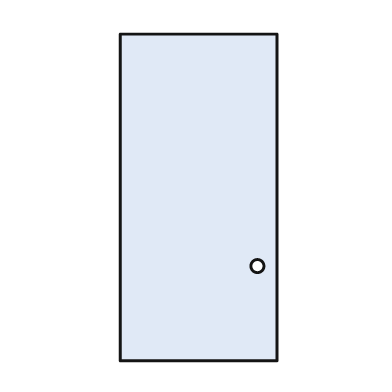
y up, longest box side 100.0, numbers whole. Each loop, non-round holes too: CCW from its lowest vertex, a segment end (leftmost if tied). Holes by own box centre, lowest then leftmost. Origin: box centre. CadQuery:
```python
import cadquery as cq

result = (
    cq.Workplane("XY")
    .moveTo(-24.0, -50.0)
    .lineTo(24.0, -50.0)
    .lineTo(24.0, 50.0)
    .lineTo(-24.0, 50.0)
    .close()
    .moveTo(18.0, -21.0)
    .circle(2.0)
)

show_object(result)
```